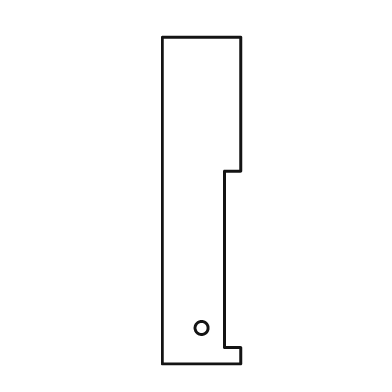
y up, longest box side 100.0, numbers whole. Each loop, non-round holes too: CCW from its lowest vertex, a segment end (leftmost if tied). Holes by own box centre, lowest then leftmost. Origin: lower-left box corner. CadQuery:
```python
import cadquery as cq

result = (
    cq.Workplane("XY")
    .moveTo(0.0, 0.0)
    .lineTo(24.0, 0.0)
    .lineTo(24.0, 5.0)
    .lineTo(19.0, 5.0)
    .lineTo(19.0, 59.0)
    .lineTo(24.0, 59.0)
    .lineTo(24.0, 100.0)
    .lineTo(0.0, 100.0)
    .close()
    .moveTo(12.0, 11.0)
    .circle(2.0)
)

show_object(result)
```